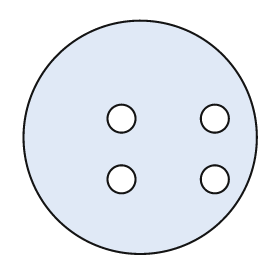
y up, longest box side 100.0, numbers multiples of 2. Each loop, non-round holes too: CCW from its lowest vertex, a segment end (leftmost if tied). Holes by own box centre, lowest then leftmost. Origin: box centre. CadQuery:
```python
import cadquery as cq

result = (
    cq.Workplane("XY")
    .moveTo(0.0, 0.0)
    .circle(50.0)
    .moveTo(-8.0, -18.0)
    .circle(6.0)
    .moveTo(32.0, -18.0)
    .circle(6.0)
    .moveTo(-8.0, 8.0)
    .circle(6.0)
    .moveTo(32.0, 8.0)
    .circle(6.0)
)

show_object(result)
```